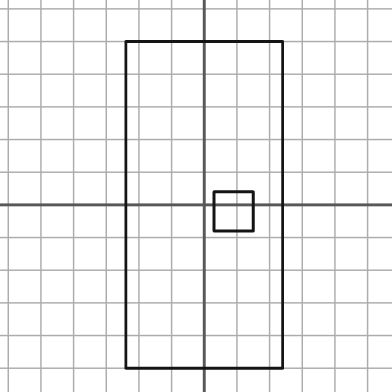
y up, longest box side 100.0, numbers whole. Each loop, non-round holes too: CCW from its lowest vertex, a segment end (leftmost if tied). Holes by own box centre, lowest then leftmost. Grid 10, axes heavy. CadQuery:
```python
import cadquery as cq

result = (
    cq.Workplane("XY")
    .moveTo(-24.0, -50.0)
    .lineTo(24.0, -50.0)
    .lineTo(24.0, 50.0)
    .lineTo(-24.0, 50.0)
    .close()
    .moveTo(3.0, -8.0)
    .lineTo(15.0, -8.0)
    .lineTo(15.0, 4.0)
    .lineTo(3.0, 4.0)
    .close()
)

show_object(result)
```